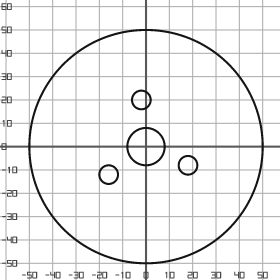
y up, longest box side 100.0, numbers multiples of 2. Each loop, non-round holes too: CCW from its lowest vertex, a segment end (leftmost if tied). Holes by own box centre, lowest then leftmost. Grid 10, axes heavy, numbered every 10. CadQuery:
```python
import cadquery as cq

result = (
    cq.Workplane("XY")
    .moveTo(0.0, 0.0)
    .circle(50.0)
    .moveTo(-16.0, -12.0)
    .circle(4.0)
    .moveTo(18.0, -8.0)
    .circle(4.0)
    .moveTo(0.0, 0.0)
    .circle(8.0)
    .moveTo(-2.0, 20.0)
    .circle(4.0)
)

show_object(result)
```